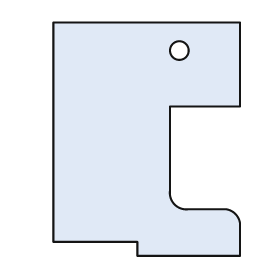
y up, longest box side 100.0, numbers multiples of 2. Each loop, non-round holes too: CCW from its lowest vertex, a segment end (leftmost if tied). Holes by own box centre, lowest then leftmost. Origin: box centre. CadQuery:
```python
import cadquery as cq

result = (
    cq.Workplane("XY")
    .moveTo(-4.0, -50.0)
    .lineTo(40.0, -50.0)
    .lineTo(40.0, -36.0)
    .threePointArc((38.0, -32.0), (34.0, -30.0))
    .lineTo(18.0, -30.0)
    .threePointArc((12.0, -28.0), (10.0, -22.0))
    .lineTo(10.0, 14.0)
    .lineTo(40.0, 14.0)
    .lineTo(40.0, 50.0)
    .lineTo(-40.0, 50.0)
    .lineTo(-40.0, -44.0)
    .lineTo(-4.0, -44.0)
    .close()
    .moveTo(14.0, 38.0)
    .circle(4.0)
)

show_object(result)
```